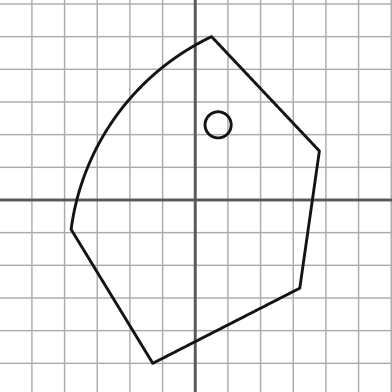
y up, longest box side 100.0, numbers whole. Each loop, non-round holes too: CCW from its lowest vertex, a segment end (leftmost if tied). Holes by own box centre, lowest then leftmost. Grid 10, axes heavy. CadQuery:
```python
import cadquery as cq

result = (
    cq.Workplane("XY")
    .moveTo(-13.0, -50.0)
    .lineTo(32.0, -27.0)
    .lineTo(38.0, 15.0)
    .lineTo(5.0, 50.0)
    .threePointArc((-24.0, 26.0), (-38.0, -9.0))
    .close()
    .moveTo(7.0, 23.0)
    .circle(4.0)
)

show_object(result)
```